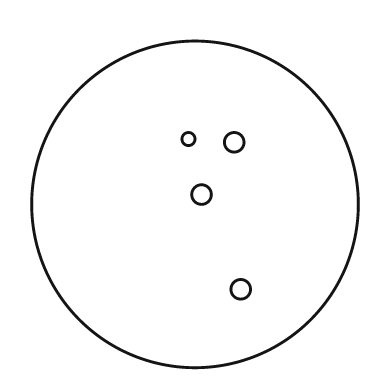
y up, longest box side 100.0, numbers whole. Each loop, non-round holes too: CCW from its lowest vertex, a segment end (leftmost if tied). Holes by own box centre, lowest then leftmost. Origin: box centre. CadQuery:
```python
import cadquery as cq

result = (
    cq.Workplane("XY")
    .moveTo(0.0, 0.0)
    .circle(50.0)
    .moveTo(14.0, -26.0)
    .circle(3.0)
    .moveTo(2.0, 3.0)
    .circle(3.0)
    .moveTo(12.0, 19.0)
    .circle(3.0)
    .moveTo(-2.0, 20.0)
    .circle(2.0)
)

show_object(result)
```